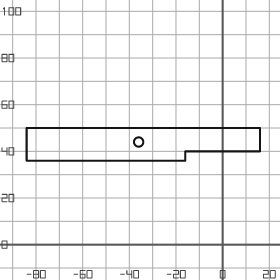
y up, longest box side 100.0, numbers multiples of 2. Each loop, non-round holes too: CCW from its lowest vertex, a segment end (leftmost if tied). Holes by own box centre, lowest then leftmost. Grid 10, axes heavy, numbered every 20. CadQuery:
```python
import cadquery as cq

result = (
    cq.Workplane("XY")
    .moveTo(-84.0, 36.0)
    .lineTo(-16.0, 36.0)
    .lineTo(-16.0, 40.0)
    .lineTo(16.0, 40.0)
    .lineTo(16.0, 50.0)
    .lineTo(-84.0, 50.0)
    .close()
    .moveTo(-36.0, 44.0)
    .circle(2.0)
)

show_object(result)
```